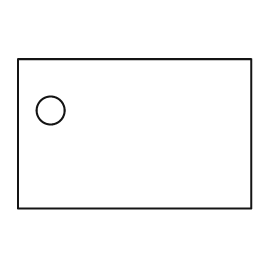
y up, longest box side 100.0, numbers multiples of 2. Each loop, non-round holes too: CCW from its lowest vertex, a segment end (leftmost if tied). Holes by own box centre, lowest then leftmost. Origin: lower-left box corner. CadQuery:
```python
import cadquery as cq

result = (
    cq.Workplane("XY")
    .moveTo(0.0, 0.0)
    .lineTo(100.0, 0.0)
    .lineTo(100.0, 64.0)
    .lineTo(0.0, 64.0)
    .close()
    .moveTo(14.0, 42.0)
    .circle(6.0)
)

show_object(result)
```